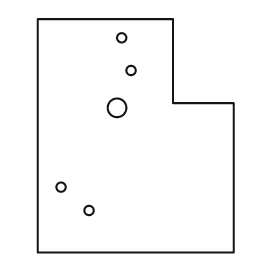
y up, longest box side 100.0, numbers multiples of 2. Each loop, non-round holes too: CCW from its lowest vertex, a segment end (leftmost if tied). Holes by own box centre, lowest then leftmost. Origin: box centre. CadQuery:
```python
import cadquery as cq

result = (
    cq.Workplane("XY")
    .moveTo(-42.0, -50.0)
    .lineTo(42.0, -50.0)
    .lineTo(42.0, 14.0)
    .lineTo(16.0, 14.0)
    .lineTo(16.0, 50.0)
    .lineTo(-42.0, 50.0)
    .close()
    .moveTo(-20.0, -32.0)
    .circle(2.0)
    .moveTo(-32.0, -22.0)
    .circle(2.0)
    .moveTo(-8.0, 12.0)
    .circle(4.0)
    .moveTo(-2.0, 28.0)
    .circle(2.0)
    .moveTo(-6.0, 42.0)
    .circle(2.0)
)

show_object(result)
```